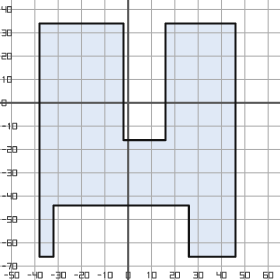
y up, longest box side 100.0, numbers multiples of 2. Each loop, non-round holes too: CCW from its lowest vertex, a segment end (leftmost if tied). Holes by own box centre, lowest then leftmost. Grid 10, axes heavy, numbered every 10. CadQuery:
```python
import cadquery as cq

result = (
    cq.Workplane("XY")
    .moveTo(-38.0, -66.0)
    .lineTo(-32.0, -66.0)
    .lineTo(-32.0, -44.0)
    .lineTo(26.0, -44.0)
    .lineTo(26.0, -66.0)
    .lineTo(46.0, -66.0)
    .lineTo(46.0, 34.0)
    .lineTo(16.0, 34.0)
    .lineTo(16.0, -16.0)
    .lineTo(-2.0, -16.0)
    .lineTo(-2.0, 34.0)
    .lineTo(-38.0, 34.0)
    .close()
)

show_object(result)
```